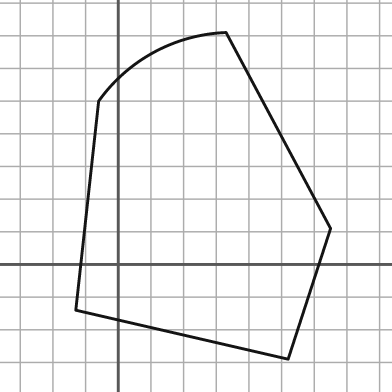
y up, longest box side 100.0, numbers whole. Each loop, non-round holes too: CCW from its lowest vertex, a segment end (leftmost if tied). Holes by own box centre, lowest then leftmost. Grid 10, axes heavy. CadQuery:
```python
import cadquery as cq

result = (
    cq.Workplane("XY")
    .moveTo(52.0, -29.0)
    .lineTo(65.0, 11.0)
    .lineTo(33.0, 71.0)
    .threePointArc((11.0, 65.0), (-6.0, 50.0))
    .lineTo(-13.0, -14.0)
    .close()
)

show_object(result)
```